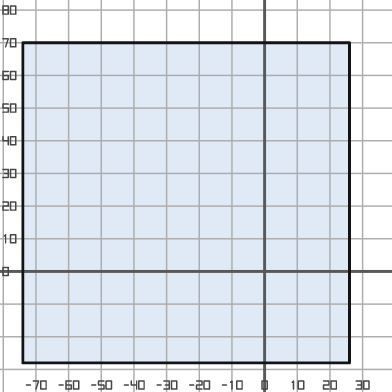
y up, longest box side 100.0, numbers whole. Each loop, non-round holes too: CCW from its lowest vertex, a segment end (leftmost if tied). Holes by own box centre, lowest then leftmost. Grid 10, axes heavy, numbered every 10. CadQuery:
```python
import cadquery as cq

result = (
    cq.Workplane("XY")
    .moveTo(-74.0, -28.0)
    .lineTo(26.0, -28.0)
    .lineTo(26.0, 70.0)
    .lineTo(-74.0, 70.0)
    .close()
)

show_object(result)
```